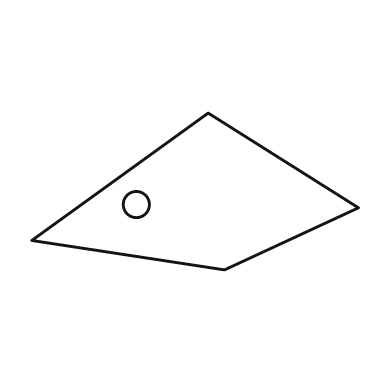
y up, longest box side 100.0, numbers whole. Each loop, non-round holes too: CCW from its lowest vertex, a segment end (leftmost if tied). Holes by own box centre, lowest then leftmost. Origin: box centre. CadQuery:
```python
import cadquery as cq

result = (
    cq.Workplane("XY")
    .moveTo(9.0, -24.0)
    .lineTo(50.0, -5.0)
    .lineTo(4.0, 24.0)
    .lineTo(-50.0, -15.0)
    .close()
    .moveTo(-18.0, -4.0)
    .circle(4.0)
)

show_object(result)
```